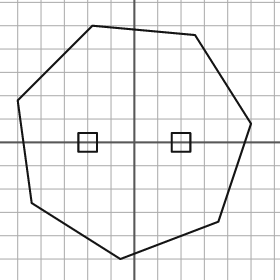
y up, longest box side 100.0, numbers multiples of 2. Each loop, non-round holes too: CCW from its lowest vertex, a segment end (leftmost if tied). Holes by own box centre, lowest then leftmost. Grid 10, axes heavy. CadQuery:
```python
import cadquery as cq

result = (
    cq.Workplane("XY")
    .moveTo(-6.0, -50.0)
    .lineTo(36.0, -34.0)
    .lineTo(50.0, 8.0)
    .lineTo(26.0, 46.0)
    .lineTo(-18.0, 50.0)
    .lineTo(-50.0, 18.0)
    .lineTo(-44.0, -26.0)
    .close()
    .moveTo(-24.0, -4.0)
    .lineTo(-16.0, -4.0)
    .lineTo(-16.0, 4.0)
    .lineTo(-24.0, 4.0)
    .close()
    .moveTo(16.0, -4.0)
    .lineTo(24.0, -4.0)
    .lineTo(24.0, 4.0)
    .lineTo(16.0, 4.0)
    .close()
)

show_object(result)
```